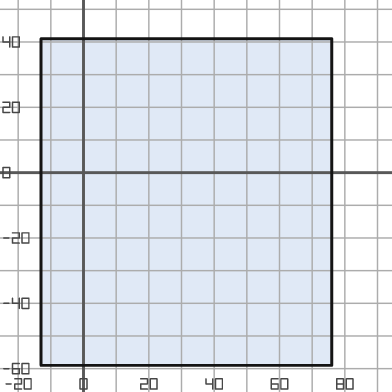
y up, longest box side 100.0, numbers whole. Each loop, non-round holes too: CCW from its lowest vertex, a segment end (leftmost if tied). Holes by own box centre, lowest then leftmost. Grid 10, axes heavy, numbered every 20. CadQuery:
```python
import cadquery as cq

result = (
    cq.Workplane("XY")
    .moveTo(-13.0, -59.0)
    .lineTo(76.0, -59.0)
    .lineTo(76.0, 41.0)
    .lineTo(-13.0, 41.0)
    .close()
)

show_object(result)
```